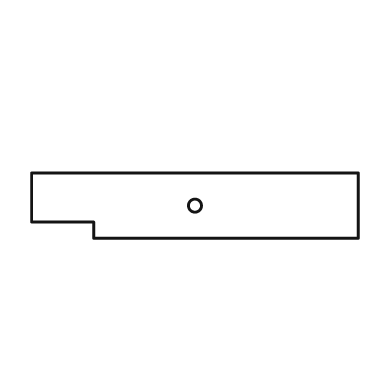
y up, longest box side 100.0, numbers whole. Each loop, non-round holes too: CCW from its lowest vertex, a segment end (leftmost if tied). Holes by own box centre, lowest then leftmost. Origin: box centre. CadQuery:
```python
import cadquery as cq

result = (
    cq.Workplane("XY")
    .moveTo(-31.0, -10.0)
    .lineTo(50.0, -10.0)
    .lineTo(50.0, 10.0)
    .lineTo(-50.0, 10.0)
    .lineTo(-50.0, -5.0)
    .lineTo(-31.0, -5.0)
    .close()
    .moveTo(0.0, 0.0)
    .circle(2.0)
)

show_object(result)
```